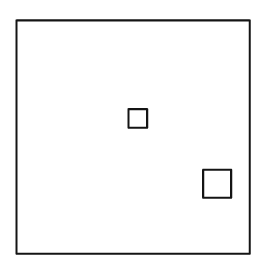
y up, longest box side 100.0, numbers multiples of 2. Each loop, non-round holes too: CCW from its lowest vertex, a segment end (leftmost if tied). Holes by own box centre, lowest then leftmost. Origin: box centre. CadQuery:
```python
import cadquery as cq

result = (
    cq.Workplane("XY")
    .moveTo(-50.0, -50.0)
    .lineTo(50.0, -50.0)
    .lineTo(50.0, 50.0)
    .lineTo(-50.0, 50.0)
    .close()
    .moveTo(30.0, -26.0)
    .lineTo(42.0, -26.0)
    .lineTo(42.0, -14.0)
    .lineTo(30.0, -14.0)
    .close()
    .moveTo(-2.0, 4.0)
    .lineTo(6.0, 4.0)
    .lineTo(6.0, 12.0)
    .lineTo(-2.0, 12.0)
    .close()
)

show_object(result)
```